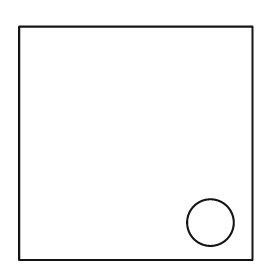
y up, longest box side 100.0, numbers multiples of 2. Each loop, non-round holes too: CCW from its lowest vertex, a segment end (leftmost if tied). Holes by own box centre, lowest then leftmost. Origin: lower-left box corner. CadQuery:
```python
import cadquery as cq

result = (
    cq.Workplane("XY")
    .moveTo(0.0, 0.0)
    .lineTo(100.0, 0.0)
    .lineTo(100.0, 100.0)
    .lineTo(0.0, 100.0)
    .close()
    .moveTo(82.0, 16.0)
    .circle(10.0)
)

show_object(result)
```